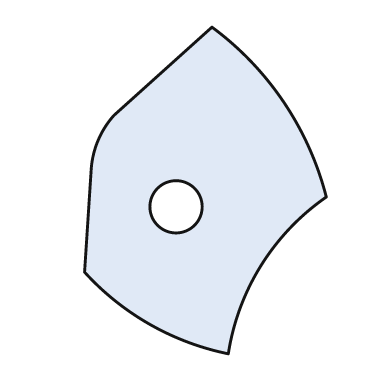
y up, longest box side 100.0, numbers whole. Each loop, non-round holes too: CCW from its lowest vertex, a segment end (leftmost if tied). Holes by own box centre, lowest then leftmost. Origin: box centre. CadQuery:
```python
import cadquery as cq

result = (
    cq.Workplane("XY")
    .moveTo(7.0, -50.0)
    .threePointArc((17.0, -23.0), (37.0, -2.0))
    .threePointArc((24.0, 27.0), (2.0, 50.0))
    .lineTo(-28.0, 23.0)
    .threePointArc((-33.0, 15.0), (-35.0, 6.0))
    .lineTo(-37.0, -25.0)
    .threePointArc((-17.0, -41.0), (7.0, -50.0))
    .close()
    .moveTo(-9.0, -5.0)
    .circle(8.0)
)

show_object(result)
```